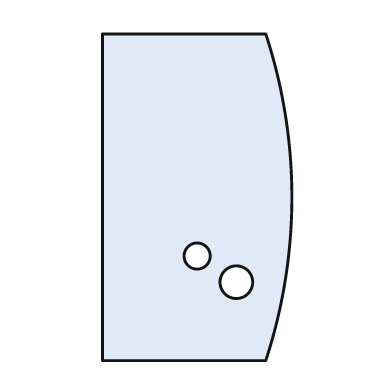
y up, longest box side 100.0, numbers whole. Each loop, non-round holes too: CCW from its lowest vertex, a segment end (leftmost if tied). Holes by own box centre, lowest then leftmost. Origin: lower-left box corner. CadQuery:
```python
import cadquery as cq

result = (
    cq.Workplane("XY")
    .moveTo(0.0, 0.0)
    .lineTo(50.0, 0.0)
    .threePointArc((58.0, 50.0), (50.0, 100.0))
    .lineTo(0.0, 100.0)
    .close()
    .moveTo(41.0, 24.0)
    .circle(5.0)
    .moveTo(29.0, 32.0)
    .circle(4.0)
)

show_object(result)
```